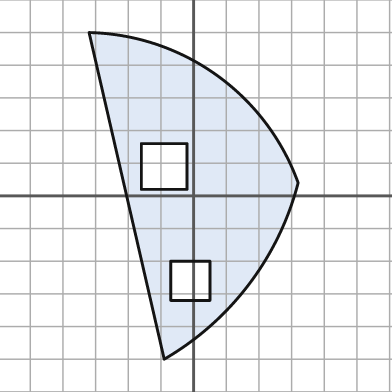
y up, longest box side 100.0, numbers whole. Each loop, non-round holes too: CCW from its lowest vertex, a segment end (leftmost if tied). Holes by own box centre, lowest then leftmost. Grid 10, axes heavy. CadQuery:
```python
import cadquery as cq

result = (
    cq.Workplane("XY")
    .moveTo(-9.0, -50.0)
    .threePointArc((17.0, -27.0), (32.0, 4.0))
    .threePointArc((7.0, 37.0), (-32.0, 50.0))
    .close()
    .moveTo(-7.0, -32.0)
    .lineTo(5.0, -32.0)
    .lineTo(5.0, -20.0)
    .lineTo(-7.0, -20.0)
    .close()
    .moveTo(-16.0, 2.0)
    .lineTo(-2.0, 2.0)
    .lineTo(-2.0, 16.0)
    .lineTo(-16.0, 16.0)
    .close()
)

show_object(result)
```